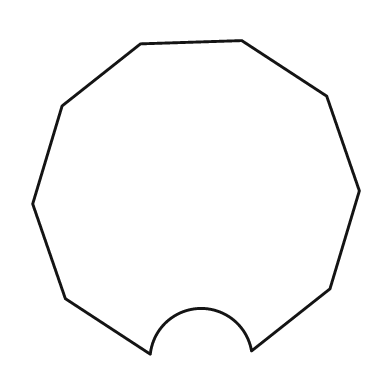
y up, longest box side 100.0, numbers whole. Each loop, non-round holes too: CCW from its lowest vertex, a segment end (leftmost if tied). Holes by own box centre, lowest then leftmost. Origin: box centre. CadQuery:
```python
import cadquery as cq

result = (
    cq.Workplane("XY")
    .moveTo(-14.0, -48.0)
    .threePointArc((1.0, -34.0), (17.0, -47.0))
    .lineTo(41.0, -28.0)
    .lineTo(50.0, 2.0)
    .lineTo(40.0, 31.0)
    .lineTo(14.0, 48.0)
    .lineTo(-17.0, 47.0)
    .lineTo(-41.0, 28.0)
    .lineTo(-50.0, -2.0)
    .lineTo(-40.0, -31.0)
    .close()
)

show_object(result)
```